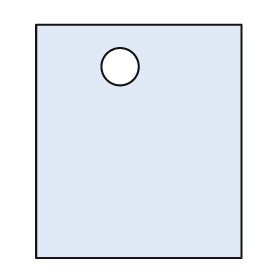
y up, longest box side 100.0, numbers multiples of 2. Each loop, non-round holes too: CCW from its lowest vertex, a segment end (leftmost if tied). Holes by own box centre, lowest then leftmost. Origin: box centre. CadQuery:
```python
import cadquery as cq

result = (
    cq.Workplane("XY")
    .moveTo(-44.0, -50.0)
    .lineTo(44.0, -50.0)
    .lineTo(44.0, 50.0)
    .lineTo(-44.0, 50.0)
    .close()
    .moveTo(-8.0, 32.0)
    .circle(8.0)
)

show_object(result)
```